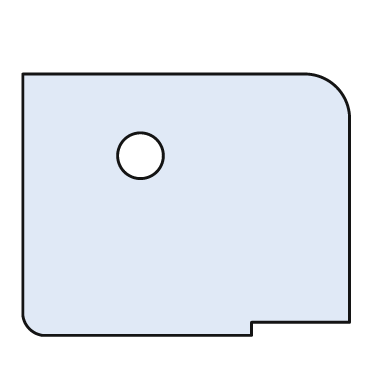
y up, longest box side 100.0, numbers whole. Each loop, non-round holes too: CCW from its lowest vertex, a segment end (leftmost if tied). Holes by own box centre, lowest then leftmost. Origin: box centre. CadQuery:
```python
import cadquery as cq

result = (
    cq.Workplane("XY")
    .moveTo(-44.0, -40.0)
    .lineTo(20.0, -40.0)
    .lineTo(20.0, -36.0)
    .lineTo(50.0, -36.0)
    .lineTo(50.0, 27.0)
    .threePointArc((46.0, 36.0), (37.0, 40.0))
    .lineTo(-50.0, 40.0)
    .lineTo(-50.0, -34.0)
    .threePointArc((-48.0, -38.0), (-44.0, -40.0))
    .close()
    .moveTo(-14.0, 15.0)
    .circle(7.0)
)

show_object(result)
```